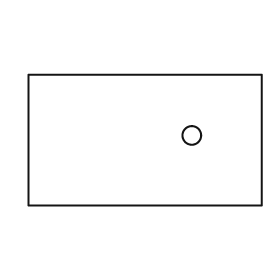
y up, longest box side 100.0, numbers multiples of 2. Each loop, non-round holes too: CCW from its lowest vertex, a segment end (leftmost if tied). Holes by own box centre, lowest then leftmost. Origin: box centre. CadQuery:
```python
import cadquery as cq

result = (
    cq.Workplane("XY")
    .moveTo(-50.0, -28.0)
    .lineTo(50.0, -28.0)
    .lineTo(50.0, 28.0)
    .lineTo(-50.0, 28.0)
    .close()
    .moveTo(20.0, 2.0)
    .circle(4.0)
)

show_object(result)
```